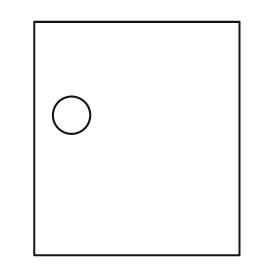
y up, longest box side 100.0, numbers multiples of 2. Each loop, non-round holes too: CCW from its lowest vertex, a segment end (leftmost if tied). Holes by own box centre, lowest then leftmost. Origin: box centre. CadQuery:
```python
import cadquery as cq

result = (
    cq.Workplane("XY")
    .moveTo(-44.0, -50.0)
    .lineTo(44.0, -50.0)
    .lineTo(44.0, 50.0)
    .lineTo(-44.0, 50.0)
    .close()
    .moveTo(-28.0, 10.0)
    .circle(8.0)
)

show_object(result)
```